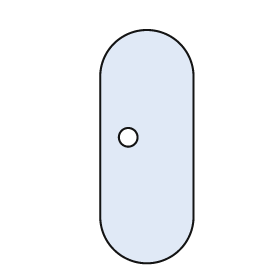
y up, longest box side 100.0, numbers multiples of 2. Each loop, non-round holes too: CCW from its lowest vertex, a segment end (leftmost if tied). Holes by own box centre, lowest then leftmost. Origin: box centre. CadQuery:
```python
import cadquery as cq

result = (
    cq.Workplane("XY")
    .moveTo(-20.0, -30.0)
    .threePointArc((0.0, -50.0), (20.0, -30.0))
    .lineTo(20.0, 30.0)
    .threePointArc((0.0, 50.0), (-20.0, 30.0))
    .close()
    .moveTo(-8.0, 4.0)
    .circle(4.0)
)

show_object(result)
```